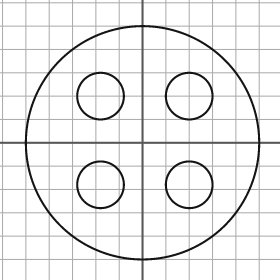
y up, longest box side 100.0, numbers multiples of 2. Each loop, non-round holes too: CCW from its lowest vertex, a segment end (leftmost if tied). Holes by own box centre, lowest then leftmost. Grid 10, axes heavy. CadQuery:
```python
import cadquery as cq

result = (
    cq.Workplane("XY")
    .moveTo(0.0, 0.0)
    .circle(50.0)
    .moveTo(-18.0, -18.0)
    .circle(10.0)
    .moveTo(20.0, -18.0)
    .circle(10.0)
    .moveTo(-18.0, 20.0)
    .circle(10.0)
    .moveTo(20.0, 20.0)
    .circle(10.0)
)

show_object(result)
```